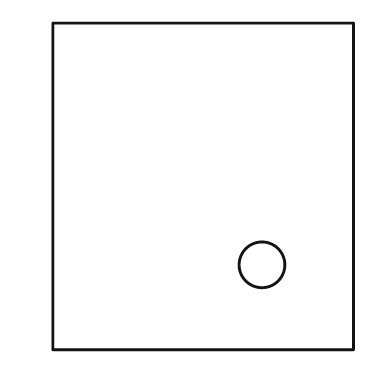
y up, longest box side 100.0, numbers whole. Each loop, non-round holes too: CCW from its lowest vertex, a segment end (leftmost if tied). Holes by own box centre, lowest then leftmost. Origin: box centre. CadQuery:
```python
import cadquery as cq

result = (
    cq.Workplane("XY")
    .moveTo(-46.0, -50.0)
    .lineTo(46.0, -50.0)
    .lineTo(46.0, 50.0)
    .lineTo(-46.0, 50.0)
    .close()
    .moveTo(18.0, -24.0)
    .circle(7.0)
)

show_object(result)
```